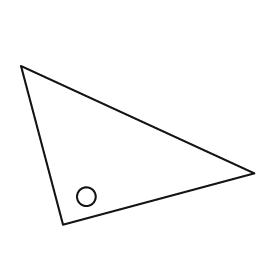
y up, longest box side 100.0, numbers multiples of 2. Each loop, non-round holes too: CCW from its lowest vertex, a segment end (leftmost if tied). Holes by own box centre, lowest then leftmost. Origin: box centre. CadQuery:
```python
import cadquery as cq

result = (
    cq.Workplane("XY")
    .moveTo(-32.0, -34.0)
    .lineTo(50.0, -12.0)
    .lineTo(-50.0, 34.0)
    .close()
    .moveTo(-22.0, -22.0)
    .circle(4.0)
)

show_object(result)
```